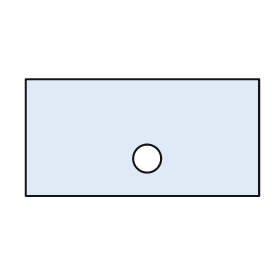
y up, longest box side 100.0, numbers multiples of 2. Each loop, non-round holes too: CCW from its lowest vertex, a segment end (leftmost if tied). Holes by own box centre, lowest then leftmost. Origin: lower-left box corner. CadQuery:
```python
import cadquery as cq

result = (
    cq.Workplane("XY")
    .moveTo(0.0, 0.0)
    .lineTo(100.0, 0.0)
    .lineTo(100.0, 50.0)
    .lineTo(0.0, 50.0)
    .close()
    .moveTo(52.0, 16.0)
    .circle(6.0)
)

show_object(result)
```